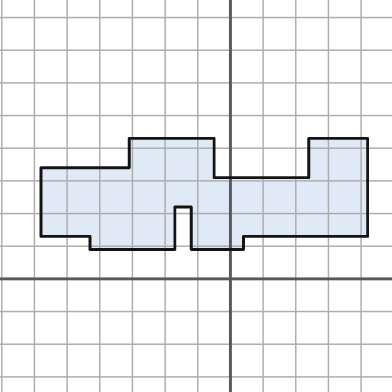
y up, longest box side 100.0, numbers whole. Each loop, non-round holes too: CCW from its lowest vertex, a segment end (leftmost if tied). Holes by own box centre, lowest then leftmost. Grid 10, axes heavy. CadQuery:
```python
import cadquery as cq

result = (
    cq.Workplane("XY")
    .moveTo(-43.0, 9.0)
    .lineTo(-17.0, 9.0)
    .lineTo(-17.0, 22.0)
    .lineTo(-12.0, 22.0)
    .lineTo(-12.0, 9.0)
    .lineTo(4.0, 9.0)
    .lineTo(4.0, 13.0)
    .lineTo(42.0, 13.0)
    .lineTo(42.0, 43.0)
    .lineTo(24.0, 43.0)
    .lineTo(24.0, 31.0)
    .lineTo(-5.0, 31.0)
    .lineTo(-5.0, 43.0)
    .lineTo(-31.0, 43.0)
    .lineTo(-31.0, 34.0)
    .lineTo(-58.0, 34.0)
    .lineTo(-58.0, 13.0)
    .lineTo(-43.0, 13.0)
    .close()
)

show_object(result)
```